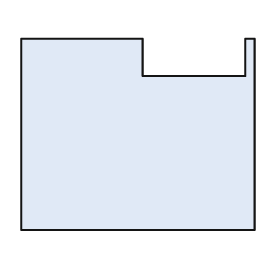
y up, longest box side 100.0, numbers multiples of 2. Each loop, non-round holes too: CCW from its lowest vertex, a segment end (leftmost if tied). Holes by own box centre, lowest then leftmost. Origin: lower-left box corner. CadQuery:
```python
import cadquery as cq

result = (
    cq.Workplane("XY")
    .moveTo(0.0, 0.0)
    .lineTo(100.0, 0.0)
    .lineTo(100.0, 82.0)
    .lineTo(96.0, 82.0)
    .lineTo(96.0, 66.0)
    .lineTo(52.0, 66.0)
    .lineTo(52.0, 82.0)
    .lineTo(0.0, 82.0)
    .close()
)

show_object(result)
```